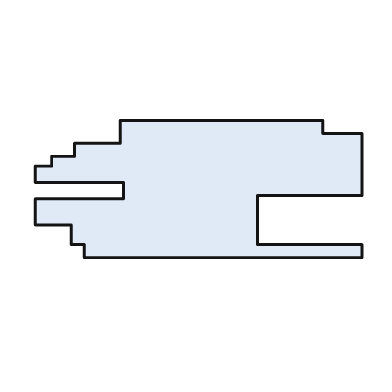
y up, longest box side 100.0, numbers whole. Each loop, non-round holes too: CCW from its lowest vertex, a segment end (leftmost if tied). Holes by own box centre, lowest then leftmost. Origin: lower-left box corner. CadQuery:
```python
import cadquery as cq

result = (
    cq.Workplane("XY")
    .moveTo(15.0, 0.0)
    .lineTo(100.0, 0.0)
    .lineTo(100.0, 4.0)
    .lineTo(68.0, 4.0)
    .lineTo(68.0, 19.0)
    .lineTo(100.0, 19.0)
    .lineTo(100.0, 38.0)
    .lineTo(88.0, 38.0)
    .lineTo(88.0, 42.0)
    .lineTo(26.0, 42.0)
    .lineTo(26.0, 35.0)
    .lineTo(12.0, 35.0)
    .lineTo(12.0, 31.0)
    .lineTo(5.0, 31.0)
    .lineTo(5.0, 28.0)
    .lineTo(0.0, 28.0)
    .lineTo(0.0, 23.0)
    .lineTo(27.0, 23.0)
    .lineTo(27.0, 18.0)
    .lineTo(0.0, 18.0)
    .lineTo(0.0, 10.0)
    .lineTo(11.0, 10.0)
    .lineTo(11.0, 4.0)
    .lineTo(15.0, 4.0)
    .close()
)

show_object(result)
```